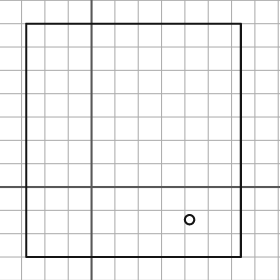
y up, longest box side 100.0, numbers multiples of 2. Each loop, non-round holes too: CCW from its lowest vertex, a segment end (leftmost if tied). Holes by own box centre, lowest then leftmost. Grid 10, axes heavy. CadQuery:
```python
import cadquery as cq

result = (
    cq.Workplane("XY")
    .moveTo(-28.0, -30.0)
    .lineTo(64.0, -30.0)
    .lineTo(64.0, 70.0)
    .lineTo(-28.0, 70.0)
    .close()
    .moveTo(42.0, -14.0)
    .circle(2.0)
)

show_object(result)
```